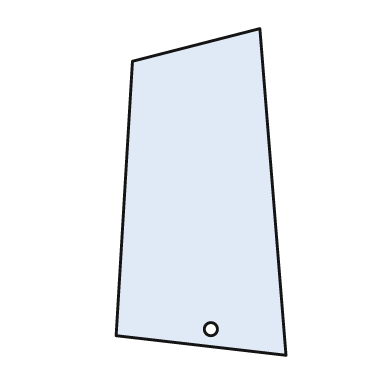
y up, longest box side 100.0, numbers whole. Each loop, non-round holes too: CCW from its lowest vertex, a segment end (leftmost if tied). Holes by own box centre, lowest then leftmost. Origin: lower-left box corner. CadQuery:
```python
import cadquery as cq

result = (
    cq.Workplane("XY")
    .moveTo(52.0, 0.0)
    .lineTo(44.0, 100.0)
    .lineTo(5.0, 90.0)
    .lineTo(0.0, 6.0)
    .close()
    .moveTo(29.0, 8.0)
    .circle(2.0)
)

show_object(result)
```